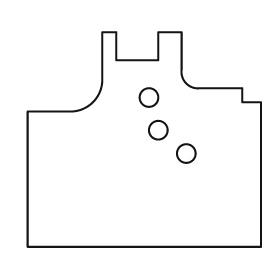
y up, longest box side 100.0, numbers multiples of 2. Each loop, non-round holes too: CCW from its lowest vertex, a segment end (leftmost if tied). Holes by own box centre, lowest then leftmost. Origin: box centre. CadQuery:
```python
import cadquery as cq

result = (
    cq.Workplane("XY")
    .moveTo(-50.0, -46.0)
    .lineTo(50.0, -46.0)
    .lineTo(50.0, 16.0)
    .lineTo(42.0, 16.0)
    .lineTo(42.0, 22.0)
    .lineTo(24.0, 22.0)
    .threePointArc((18.0, 24.0), (16.0, 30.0))
    .lineTo(16.0, 46.0)
    .lineTo(6.0, 46.0)
    .lineTo(6.0, 34.0)
    .lineTo(-12.0, 34.0)
    .lineTo(-12.0, 46.0)
    .lineTo(-18.0, 46.0)
    .lineTo(-18.0, 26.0)
    .threePointArc((-22.0, 16.0), (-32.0, 12.0))
    .lineTo(-50.0, 12.0)
    .close()
    .moveTo(18.0, -6.0)
    .circle(4.0)
    .moveTo(6.0, 4.0)
    .circle(4.0)
    .moveTo(2.0, 18.0)
    .circle(4.0)
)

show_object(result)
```